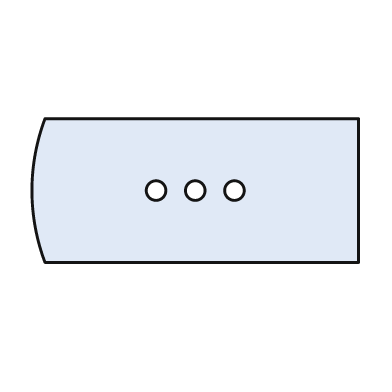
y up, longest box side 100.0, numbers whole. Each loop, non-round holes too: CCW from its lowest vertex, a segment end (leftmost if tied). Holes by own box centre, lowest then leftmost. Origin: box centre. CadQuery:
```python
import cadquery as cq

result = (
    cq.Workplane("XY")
    .moveTo(-46.0, -22.0)
    .lineTo(50.0, -22.0)
    .lineTo(50.0, 22.0)
    .lineTo(-46.0, 22.0)
    .threePointArc((-50.0, 0.0), (-46.0, -22.0))
    .close()
    .moveTo(-12.0, 0.0)
    .circle(3.0)
    .moveTo(0.0, 0.0)
    .circle(3.0)
    .moveTo(12.0, 0.0)
    .circle(3.0)
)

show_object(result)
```